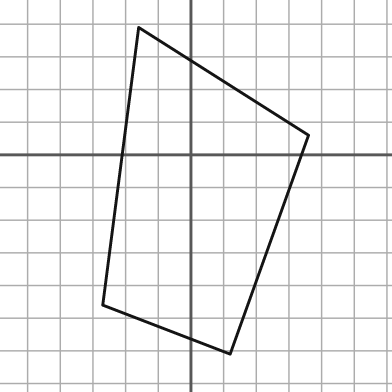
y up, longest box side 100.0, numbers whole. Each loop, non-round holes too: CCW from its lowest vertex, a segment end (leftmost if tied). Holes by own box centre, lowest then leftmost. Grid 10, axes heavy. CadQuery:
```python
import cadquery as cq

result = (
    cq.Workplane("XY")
    .moveTo(12.0, -61.0)
    .lineTo(36.0, 6.0)
    .lineTo(-16.0, 39.0)
    .lineTo(-27.0, -46.0)
    .close()
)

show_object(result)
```